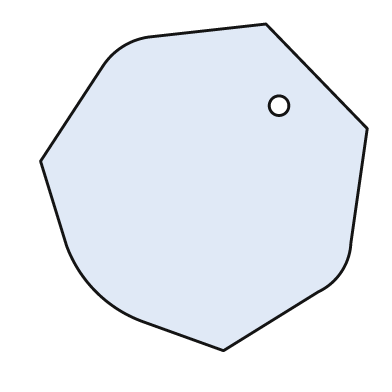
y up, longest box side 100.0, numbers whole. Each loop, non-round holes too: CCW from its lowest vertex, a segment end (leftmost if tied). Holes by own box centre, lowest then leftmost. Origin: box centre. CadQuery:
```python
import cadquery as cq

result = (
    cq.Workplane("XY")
    .moveTo(6.0, -50.0)
    .lineTo(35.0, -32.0)
    .threePointArc((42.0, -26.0), (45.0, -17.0))
    .lineTo(50.0, 18.0)
    .lineTo(19.0, 50.0)
    .lineTo(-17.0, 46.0)
    .threePointArc((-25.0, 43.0), (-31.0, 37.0))
    .lineTo(-50.0, 8.0)
    .lineTo(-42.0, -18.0)
    .threePointArc((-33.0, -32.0), (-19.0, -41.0))
    .close()
    .moveTo(23.0, 25.0)
    .circle(3.0)
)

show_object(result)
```